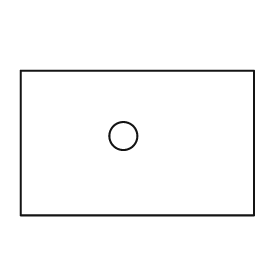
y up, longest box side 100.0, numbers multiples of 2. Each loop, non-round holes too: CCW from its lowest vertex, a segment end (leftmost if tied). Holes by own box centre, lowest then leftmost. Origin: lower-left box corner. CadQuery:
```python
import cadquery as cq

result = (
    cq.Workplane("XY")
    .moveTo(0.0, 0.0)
    .lineTo(100.0, 0.0)
    .lineTo(100.0, 62.0)
    .lineTo(0.0, 62.0)
    .close()
    .moveTo(44.0, 34.0)
    .circle(6.0)
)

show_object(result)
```